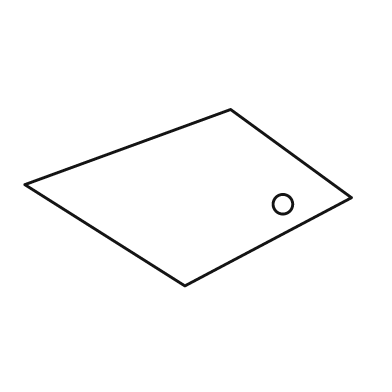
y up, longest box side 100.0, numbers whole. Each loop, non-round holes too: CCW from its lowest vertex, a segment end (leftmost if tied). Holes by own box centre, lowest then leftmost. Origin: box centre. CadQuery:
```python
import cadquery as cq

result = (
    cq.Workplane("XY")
    .moveTo(-1.0, -27.0)
    .lineTo(50.0, 0.0)
    .lineTo(13.0, 27.0)
    .lineTo(-50.0, 4.0)
    .close()
    .moveTo(29.0, -2.0)
    .circle(3.0)
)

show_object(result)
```